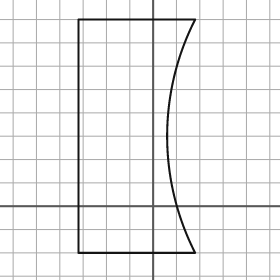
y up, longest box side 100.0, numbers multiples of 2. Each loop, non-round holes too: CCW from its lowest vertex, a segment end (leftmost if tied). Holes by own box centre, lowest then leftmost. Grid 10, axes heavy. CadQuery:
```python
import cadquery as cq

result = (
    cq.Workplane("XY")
    .moveTo(-32.0, -20.0)
    .lineTo(18.0, -20.0)
    .threePointArc((6.0, 30.0), (18.0, 80.0))
    .lineTo(-32.0, 80.0)
    .close()
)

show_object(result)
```